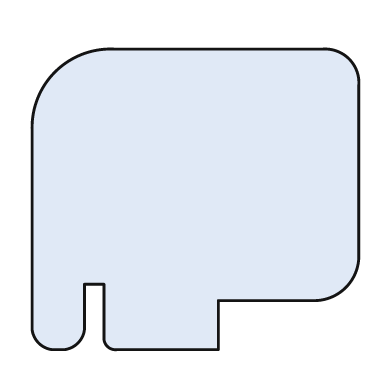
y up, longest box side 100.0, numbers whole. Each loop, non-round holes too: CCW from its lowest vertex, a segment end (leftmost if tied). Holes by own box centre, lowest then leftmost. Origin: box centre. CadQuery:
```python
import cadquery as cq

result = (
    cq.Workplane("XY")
    .moveTo(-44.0, -46.0)
    .lineTo(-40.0, -46.0)
    .threePointArc((-36.0, -44.0), (-34.0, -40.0))
    .lineTo(-34.0, -26.0)
    .lineTo(-28.0, -26.0)
    .lineTo(-28.0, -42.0)
    .threePointArc((-27.0, -45.0), (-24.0, -46.0))
    .lineTo(7.0, -46.0)
    .lineTo(7.0, -31.0)
    .lineTo(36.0, -31.0)
    .threePointArc((46.0, -27.0), (50.0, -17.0))
    .lineTo(50.0, 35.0)
    .threePointArc((47.0, 43.0), (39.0, 46.0))
    .lineTo(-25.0, 46.0)
    .threePointArc((-43.0, 39.0), (-50.0, 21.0))
    .lineTo(-50.0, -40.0)
    .threePointArc((-48.0, -44.0), (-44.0, -46.0))
    .close()
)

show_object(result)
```